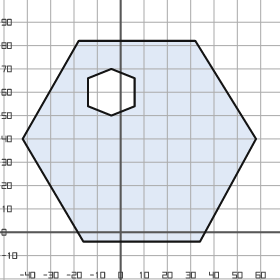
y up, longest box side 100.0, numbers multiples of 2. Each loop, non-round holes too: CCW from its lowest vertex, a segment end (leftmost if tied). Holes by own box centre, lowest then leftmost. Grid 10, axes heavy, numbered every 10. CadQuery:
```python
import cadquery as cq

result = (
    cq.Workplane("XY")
    .moveTo(-16.0, -4.0)
    .lineTo(34.0, -4.0)
    .lineTo(58.0, 40.0)
    .lineTo(32.0, 82.0)
    .lineTo(-18.0, 82.0)
    .lineTo(-42.0, 40.0)
    .close()
    .moveTo(-4.0, 50.0)
    .lineTo(6.0, 54.0)
    .lineTo(6.0, 66.0)
    .lineTo(-4.0, 70.0)
    .lineTo(-14.0, 66.0)
    .lineTo(-14.0, 54.0)
    .close()
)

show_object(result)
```